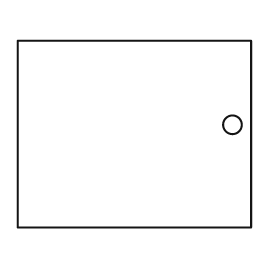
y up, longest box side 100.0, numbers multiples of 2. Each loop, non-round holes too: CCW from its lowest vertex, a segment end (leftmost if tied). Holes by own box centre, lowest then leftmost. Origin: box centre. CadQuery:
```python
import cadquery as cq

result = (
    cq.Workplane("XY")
    .moveTo(-50.0, -40.0)
    .lineTo(50.0, -40.0)
    .lineTo(50.0, 40.0)
    .lineTo(-50.0, 40.0)
    .close()
    .moveTo(42.0, 4.0)
    .circle(4.0)
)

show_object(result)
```